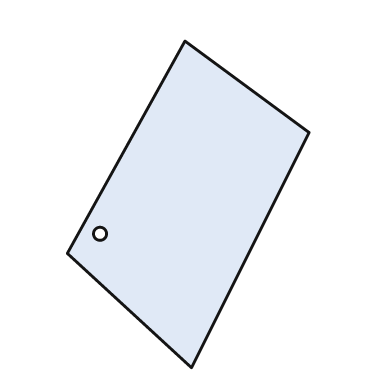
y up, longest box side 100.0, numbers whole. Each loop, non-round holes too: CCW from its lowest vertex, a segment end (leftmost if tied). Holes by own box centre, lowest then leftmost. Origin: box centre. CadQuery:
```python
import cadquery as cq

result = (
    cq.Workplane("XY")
    .moveTo(1.0, -50.0)
    .lineTo(37.0, 22.0)
    .lineTo(-1.0, 50.0)
    .lineTo(-37.0, -15.0)
    .close()
    .moveTo(-27.0, -9.0)
    .circle(2.0)
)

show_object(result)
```